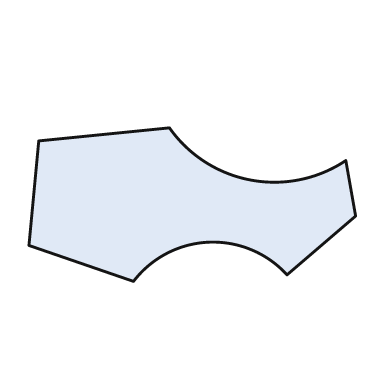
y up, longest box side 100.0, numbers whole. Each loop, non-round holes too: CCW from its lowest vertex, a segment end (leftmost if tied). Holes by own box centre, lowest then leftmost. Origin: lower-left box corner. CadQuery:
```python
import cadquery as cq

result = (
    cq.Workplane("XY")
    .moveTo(32.0, 0.0)
    .threePointArc((55.0, 12.0), (79.0, 2.0))
    .lineTo(100.0, 20.0)
    .lineTo(97.0, 37.0)
    .threePointArc((68.0, 31.0), (43.0, 47.0))
    .lineTo(3.0, 43.0)
    .lineTo(0.0, 11.0)
    .close()
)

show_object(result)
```